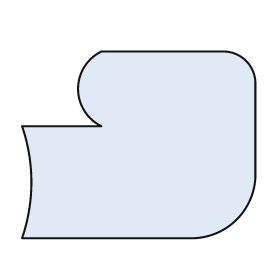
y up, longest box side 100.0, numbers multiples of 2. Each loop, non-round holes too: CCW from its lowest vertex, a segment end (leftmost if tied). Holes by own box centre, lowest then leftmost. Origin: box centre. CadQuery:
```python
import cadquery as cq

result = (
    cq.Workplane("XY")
    .moveTo(-50.0, -40.0)
    .lineTo(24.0, -40.0)
    .threePointArc((42.0, -32.0), (50.0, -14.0))
    .lineTo(50.0, 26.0)
    .threePointArc((46.0, 36.0), (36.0, 40.0))
    .lineTo(-16.0, 40.0)
    .threePointArc((-26.0, 24.0), (-16.0, 8.0))
    .lineTo(-50.0, 8.0)
    .threePointArc((-46.0, -16.0), (-50.0, -40.0))
    .close()
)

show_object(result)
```